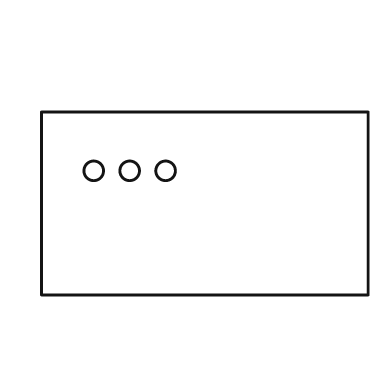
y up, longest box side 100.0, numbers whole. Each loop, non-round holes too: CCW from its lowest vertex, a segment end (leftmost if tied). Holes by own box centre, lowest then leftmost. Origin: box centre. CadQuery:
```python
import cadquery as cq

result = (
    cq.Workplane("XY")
    .moveTo(-50.0, -28.0)
    .lineTo(50.0, -28.0)
    .lineTo(50.0, 28.0)
    .lineTo(-50.0, 28.0)
    .close()
    .moveTo(-34.0, 10.0)
    .circle(3.0)
    .moveTo(-23.0, 10.0)
    .circle(3.0)
    .moveTo(-12.0, 10.0)
    .circle(3.0)
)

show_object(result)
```